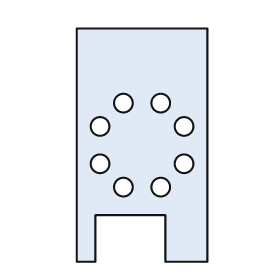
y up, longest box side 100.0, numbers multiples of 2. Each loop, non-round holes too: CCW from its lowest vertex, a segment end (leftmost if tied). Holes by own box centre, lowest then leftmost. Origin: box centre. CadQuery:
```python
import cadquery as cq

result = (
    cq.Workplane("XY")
    .moveTo(-28.0, -50.0)
    .lineTo(-20.0, -50.0)
    .lineTo(-20.0, -30.0)
    .lineTo(10.0, -30.0)
    .lineTo(10.0, -50.0)
    .lineTo(28.0, -50.0)
    .lineTo(28.0, 50.0)
    .lineTo(-28.0, 50.0)
    .close()
    .moveTo(-8.0, -18.0)
    .circle(4.0)
    .moveTo(8.0, -18.0)
    .circle(4.0)
    .moveTo(-18.0, -8.0)
    .circle(4.0)
    .moveTo(18.0, -8.0)
    .circle(4.0)
    .moveTo(-18.0, 8.0)
    .circle(4.0)
    .moveTo(18.0, 8.0)
    .circle(4.0)
    .moveTo(-8.0, 18.0)
    .circle(4.0)
    .moveTo(8.0, 18.0)
    .circle(4.0)
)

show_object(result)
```